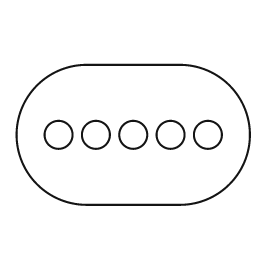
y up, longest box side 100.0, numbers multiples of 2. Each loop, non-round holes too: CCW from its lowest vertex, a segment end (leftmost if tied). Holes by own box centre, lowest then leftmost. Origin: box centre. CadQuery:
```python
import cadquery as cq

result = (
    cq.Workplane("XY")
    .moveTo(-20.0, -30.0)
    .lineTo(20.0, -30.0)
    .threePointArc((50.0, 0.0), (20.0, 30.0))
    .lineTo(-20.0, 30.0)
    .threePointArc((-50.0, 0.0), (-20.0, -30.0))
    .close()
    .moveTo(-32.0, 0.0)
    .circle(6.0)
    .moveTo(-16.0, 0.0)
    .circle(6.0)
    .moveTo(0.0, 0.0)
    .circle(6.0)
    .moveTo(16.0, 0.0)
    .circle(6.0)
    .moveTo(32.0, 0.0)
    .circle(6.0)
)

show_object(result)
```